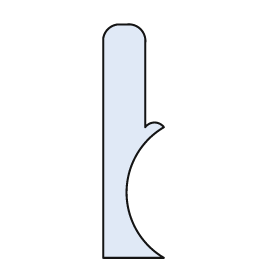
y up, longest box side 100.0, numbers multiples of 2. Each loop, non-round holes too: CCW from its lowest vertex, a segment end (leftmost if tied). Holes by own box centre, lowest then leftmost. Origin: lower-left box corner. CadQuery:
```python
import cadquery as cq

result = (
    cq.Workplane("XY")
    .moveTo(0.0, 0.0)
    .lineTo(26.0, 0.0)
    .threePointArc((10.0, 28.0), (26.0, 56.0))
    .threePointArc((22.0, 58.0), (18.0, 56.0))
    .lineTo(18.0, 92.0)
    .threePointArc((16.0, 98.0), (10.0, 100.0))
    .lineTo(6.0, 100.0)
    .threePointArc((2.0, 98.0), (0.0, 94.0))
    .close()
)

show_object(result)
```